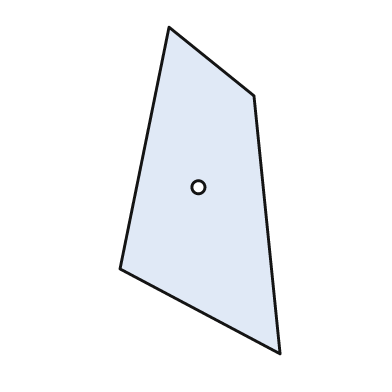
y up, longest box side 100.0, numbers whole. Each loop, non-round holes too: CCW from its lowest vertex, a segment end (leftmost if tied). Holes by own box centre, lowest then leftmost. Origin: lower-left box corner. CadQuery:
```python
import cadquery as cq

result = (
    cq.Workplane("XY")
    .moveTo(49.0, 0.0)
    .lineTo(41.0, 79.0)
    .lineTo(15.0, 100.0)
    .lineTo(0.0, 26.0)
    .close()
    .moveTo(24.0, 51.0)
    .circle(2.0)
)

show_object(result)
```